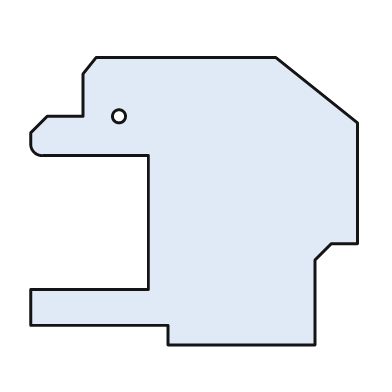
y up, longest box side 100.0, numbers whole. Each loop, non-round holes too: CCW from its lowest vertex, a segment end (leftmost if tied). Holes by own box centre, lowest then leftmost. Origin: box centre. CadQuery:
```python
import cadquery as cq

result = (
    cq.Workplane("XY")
    .moveTo(-8.0, -44.0)
    .lineTo(37.0, -44.0)
    .lineTo(37.0, -18.0)
    .lineTo(42.0, -13.0)
    .lineTo(50.0, -13.0)
    .lineTo(50.0, 24.0)
    .lineTo(25.0, 44.0)
    .lineTo(-30.0, 44.0)
    .lineTo(-34.0, 39.0)
    .lineTo(-34.0, 26.0)
    .lineTo(-45.0, 26.0)
    .lineTo(-50.0, 21.0)
    .lineTo(-50.0, 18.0)
    .threePointArc((-49.0, 15.0), (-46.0, 14.0))
    .lineTo(-14.0, 14.0)
    .lineTo(-14.0, -27.0)
    .lineTo(-50.0, -27.0)
    .lineTo(-50.0, -38.0)
    .lineTo(-8.0, -38.0)
    .close()
    .moveTo(-23.0, 26.0)
    .circle(2.0)
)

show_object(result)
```